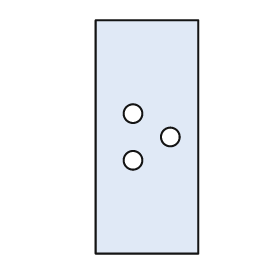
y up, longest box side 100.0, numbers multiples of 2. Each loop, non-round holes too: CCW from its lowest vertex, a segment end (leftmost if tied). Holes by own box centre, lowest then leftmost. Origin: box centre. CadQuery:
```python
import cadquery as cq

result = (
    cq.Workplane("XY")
    .moveTo(-22.0, -50.0)
    .lineTo(22.0, -50.0)
    .lineTo(22.0, 50.0)
    .lineTo(-22.0, 50.0)
    .close()
    .moveTo(-6.0, -10.0)
    .circle(4.0)
    .moveTo(10.0, 0.0)
    .circle(4.0)
    .moveTo(-6.0, 10.0)
    .circle(4.0)
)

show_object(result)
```